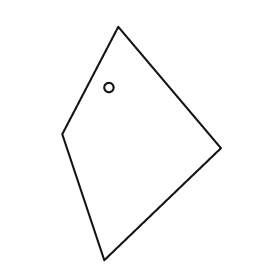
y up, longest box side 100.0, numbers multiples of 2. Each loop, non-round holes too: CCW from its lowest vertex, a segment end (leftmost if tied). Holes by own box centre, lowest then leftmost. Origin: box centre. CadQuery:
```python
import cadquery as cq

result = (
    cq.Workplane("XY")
    .moveTo(-16.0, -50.0)
    .lineTo(34.0, -2.0)
    .lineTo(-10.0, 50.0)
    .lineTo(-34.0, 4.0)
    .close()
    .moveTo(-14.0, 24.0)
    .circle(2.0)
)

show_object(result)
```